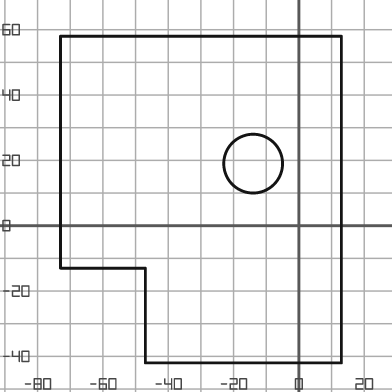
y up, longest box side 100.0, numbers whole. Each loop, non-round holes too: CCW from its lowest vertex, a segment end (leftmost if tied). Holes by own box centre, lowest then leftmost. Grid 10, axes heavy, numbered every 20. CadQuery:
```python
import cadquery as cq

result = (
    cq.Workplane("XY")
    .moveTo(-47.0, -42.0)
    .lineTo(13.0, -42.0)
    .lineTo(13.0, 58.0)
    .lineTo(-73.0, 58.0)
    .lineTo(-73.0, -13.0)
    .lineTo(-47.0, -13.0)
    .close()
    .moveTo(-14.0, 19.0)
    .circle(9.0)
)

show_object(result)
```